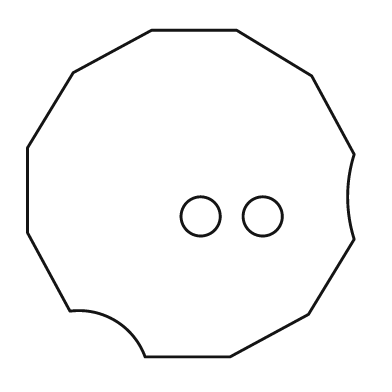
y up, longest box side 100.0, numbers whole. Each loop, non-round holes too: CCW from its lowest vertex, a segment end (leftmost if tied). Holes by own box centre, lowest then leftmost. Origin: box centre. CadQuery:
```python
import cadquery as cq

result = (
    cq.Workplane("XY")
    .moveTo(-14.0, -50.0)
    .lineTo(12.0, -50.0)
    .lineTo(36.0, -37.0)
    .lineTo(50.0, -14.0)
    .threePointArc((48.0, -1.0), (50.0, 12.0))
    .lineTo(37.0, 36.0)
    .lineTo(14.0, 50.0)
    .lineTo(-12.0, 50.0)
    .lineTo(-36.0, 37.0)
    .lineTo(-50.0, 14.0)
    .lineTo(-50.0, -12.0)
    .lineTo(-37.0, -36.0)
    .threePointArc((-23.0, -39.0), (-14.0, -50.0))
    .close()
    .moveTo(3.0, -7.0)
    .circle(6.0)
    .moveTo(22.0, -7.0)
    .circle(6.0)
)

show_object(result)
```